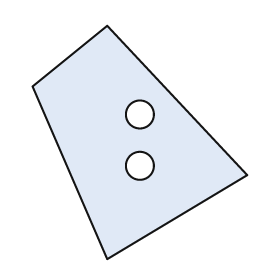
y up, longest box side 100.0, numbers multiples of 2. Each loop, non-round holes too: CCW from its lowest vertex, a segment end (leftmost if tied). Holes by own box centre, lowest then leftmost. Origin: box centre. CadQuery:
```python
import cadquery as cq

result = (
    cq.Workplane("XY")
    .moveTo(-14.0, -50.0)
    .lineTo(46.0, -14.0)
    .lineTo(-14.0, 50.0)
    .lineTo(-46.0, 24.0)
    .close()
    .moveTo(0.0, -10.0)
    .circle(6.0)
    .moveTo(0.0, 12.0)
    .circle(6.0)
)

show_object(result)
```